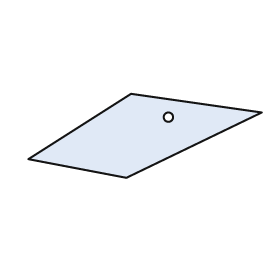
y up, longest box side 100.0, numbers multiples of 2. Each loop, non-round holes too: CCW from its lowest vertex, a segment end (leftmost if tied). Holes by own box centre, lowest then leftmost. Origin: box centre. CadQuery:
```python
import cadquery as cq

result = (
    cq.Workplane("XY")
    .moveTo(-8.0, -18.0)
    .lineTo(50.0, 10.0)
    .lineTo(-6.0, 18.0)
    .lineTo(-50.0, -10.0)
    .close()
    .moveTo(10.0, 8.0)
    .circle(2.0)
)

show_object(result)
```